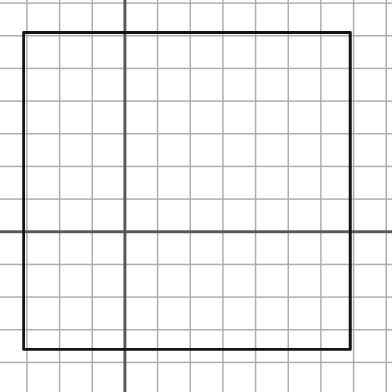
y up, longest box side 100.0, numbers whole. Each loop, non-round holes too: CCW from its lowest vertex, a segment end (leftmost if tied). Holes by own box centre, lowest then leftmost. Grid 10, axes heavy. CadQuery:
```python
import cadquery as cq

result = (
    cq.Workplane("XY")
    .moveTo(-31.0, -36.0)
    .lineTo(69.0, -36.0)
    .lineTo(69.0, 61.0)
    .lineTo(-31.0, 61.0)
    .close()
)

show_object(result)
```